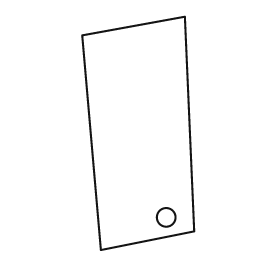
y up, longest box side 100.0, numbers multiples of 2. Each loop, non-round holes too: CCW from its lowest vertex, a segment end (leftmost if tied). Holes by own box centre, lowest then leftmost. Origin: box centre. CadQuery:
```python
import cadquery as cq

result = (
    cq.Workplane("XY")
    .moveTo(-16.0, -50.0)
    .lineTo(24.0, -42.0)
    .lineTo(20.0, 50.0)
    .lineTo(-24.0, 42.0)
    .close()
    .moveTo(12.0, -36.0)
    .circle(4.0)
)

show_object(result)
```